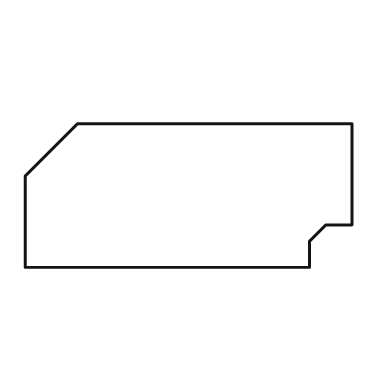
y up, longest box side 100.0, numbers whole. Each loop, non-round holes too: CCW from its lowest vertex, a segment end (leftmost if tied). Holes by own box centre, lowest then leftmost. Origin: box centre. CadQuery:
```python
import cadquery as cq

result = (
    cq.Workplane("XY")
    .moveTo(-50.0, -22.0)
    .lineTo(37.0, -22.0)
    .lineTo(37.0, -14.0)
    .lineTo(42.0, -9.0)
    .lineTo(50.0, -9.0)
    .lineTo(50.0, 22.0)
    .lineTo(-34.0, 22.0)
    .lineTo(-50.0, 6.0)
    .close()
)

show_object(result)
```